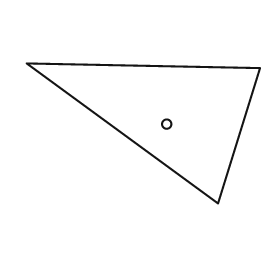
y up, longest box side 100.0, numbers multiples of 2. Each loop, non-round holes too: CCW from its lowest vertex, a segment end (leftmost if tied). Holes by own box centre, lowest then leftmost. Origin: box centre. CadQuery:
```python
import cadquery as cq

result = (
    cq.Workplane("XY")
    .moveTo(32.0, -30.0)
    .lineTo(50.0, 28.0)
    .lineTo(-50.0, 30.0)
    .close()
    .moveTo(10.0, 4.0)
    .circle(2.0)
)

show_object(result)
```